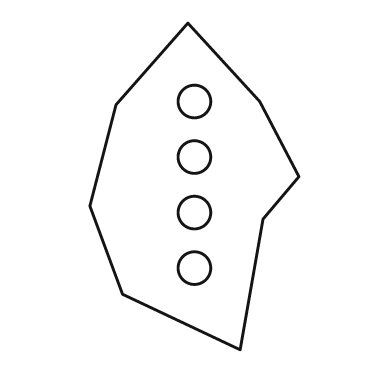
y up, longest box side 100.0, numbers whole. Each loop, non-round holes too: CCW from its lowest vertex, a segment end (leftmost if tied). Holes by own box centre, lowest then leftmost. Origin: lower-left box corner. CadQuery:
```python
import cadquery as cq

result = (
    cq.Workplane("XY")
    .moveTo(46.0, 0.0)
    .lineTo(53.0, 40.0)
    .lineTo(64.0, 53.0)
    .lineTo(52.0, 76.0)
    .lineTo(30.0, 100.0)
    .lineTo(8.0, 75.0)
    .lineTo(0.0, 44.0)
    .lineTo(10.0, 17.0)
    .close()
    .moveTo(32.0, 25.0)
    .circle(5.0)
    .moveTo(32.0, 42.0)
    .circle(5.0)
    .moveTo(32.0, 59.0)
    .circle(5.0)
    .moveTo(32.0, 76.0)
    .circle(5.0)
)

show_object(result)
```